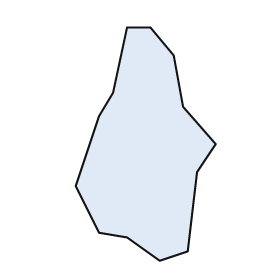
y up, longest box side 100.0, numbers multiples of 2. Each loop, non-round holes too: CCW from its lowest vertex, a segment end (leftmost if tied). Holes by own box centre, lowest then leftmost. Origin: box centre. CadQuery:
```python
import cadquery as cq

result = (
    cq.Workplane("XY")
    .moveTo(6.0, -50.0)
    .lineTo(18.0, -46.0)
    .lineTo(22.0, -12.0)
    .lineTo(30.0, 0.0)
    .lineTo(16.0, 16.0)
    .lineTo(12.0, 38.0)
    .lineTo(2.0, 50.0)
    .lineTo(-8.0, 50.0)
    .lineTo(-14.0, 22.0)
    .lineTo(-20.0, 12.0)
    .lineTo(-30.0, -18.0)
    .lineTo(-20.0, -38.0)
    .lineTo(-8.0, -40.0)
    .close()
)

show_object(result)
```